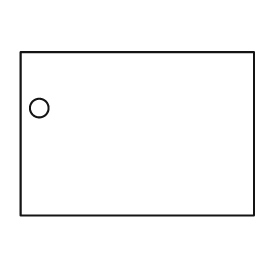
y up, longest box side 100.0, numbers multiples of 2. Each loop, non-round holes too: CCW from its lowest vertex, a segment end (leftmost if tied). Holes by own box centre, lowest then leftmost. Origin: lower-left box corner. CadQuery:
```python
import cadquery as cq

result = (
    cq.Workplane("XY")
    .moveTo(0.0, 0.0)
    .lineTo(100.0, 0.0)
    .lineTo(100.0, 70.0)
    .lineTo(0.0, 70.0)
    .close()
    .moveTo(8.0, 46.0)
    .circle(4.0)
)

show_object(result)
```